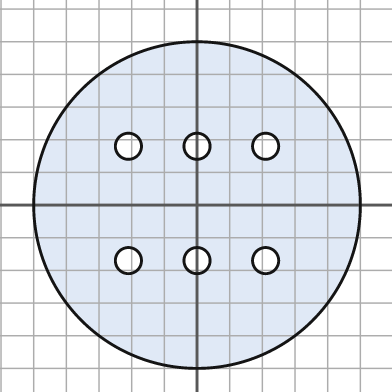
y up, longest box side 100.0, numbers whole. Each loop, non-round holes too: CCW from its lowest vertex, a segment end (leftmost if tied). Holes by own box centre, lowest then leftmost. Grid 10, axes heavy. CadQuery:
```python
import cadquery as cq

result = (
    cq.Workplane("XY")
    .moveTo(0.0, 0.0)
    .circle(50.0)
    .moveTo(-21.0, -17.0)
    .circle(4.0)
    .moveTo(0.0, -17.0)
    .circle(4.0)
    .moveTo(21.0, -17.0)
    .circle(4.0)
    .moveTo(-21.0, 18.0)
    .circle(4.0)
    .moveTo(0.0, 18.0)
    .circle(4.0)
    .moveTo(21.0, 18.0)
    .circle(4.0)
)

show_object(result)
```